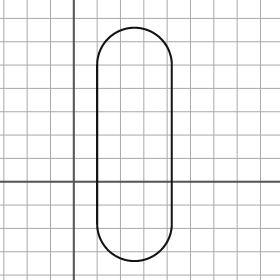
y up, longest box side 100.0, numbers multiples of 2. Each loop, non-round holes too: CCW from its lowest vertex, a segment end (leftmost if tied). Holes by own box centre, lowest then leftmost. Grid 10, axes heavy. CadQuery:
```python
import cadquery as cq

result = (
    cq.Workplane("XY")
    .moveTo(10.0, -18.0)
    .threePointArc((26.0, -34.0), (42.0, -18.0))
    .lineTo(42.0, 50.0)
    .threePointArc((26.0, 66.0), (10.0, 50.0))
    .close()
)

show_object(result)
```